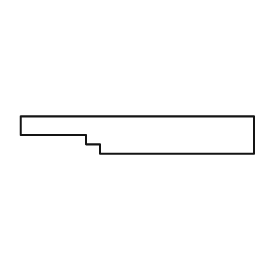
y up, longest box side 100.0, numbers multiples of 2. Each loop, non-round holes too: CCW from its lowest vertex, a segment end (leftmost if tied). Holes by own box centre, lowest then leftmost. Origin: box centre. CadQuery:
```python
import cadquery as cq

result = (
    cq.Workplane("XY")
    .moveTo(-16.0, -8.0)
    .lineTo(50.0, -8.0)
    .lineTo(50.0, 8.0)
    .lineTo(-50.0, 8.0)
    .lineTo(-50.0, 0.0)
    .lineTo(-22.0, 0.0)
    .lineTo(-22.0, -4.0)
    .lineTo(-16.0, -4.0)
    .close()
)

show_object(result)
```